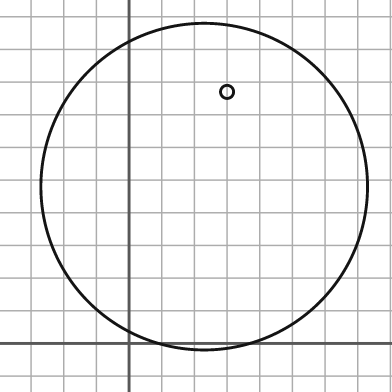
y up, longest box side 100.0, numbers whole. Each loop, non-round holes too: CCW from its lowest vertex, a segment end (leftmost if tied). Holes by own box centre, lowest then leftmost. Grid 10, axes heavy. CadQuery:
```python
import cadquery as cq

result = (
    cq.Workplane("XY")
    .moveTo(23.0, 48.0)
    .circle(50.0)
    .moveTo(30.0, 77.0)
    .circle(2.0)
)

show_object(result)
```